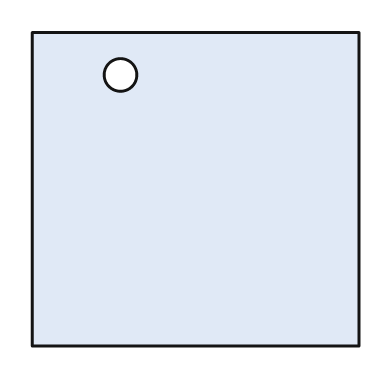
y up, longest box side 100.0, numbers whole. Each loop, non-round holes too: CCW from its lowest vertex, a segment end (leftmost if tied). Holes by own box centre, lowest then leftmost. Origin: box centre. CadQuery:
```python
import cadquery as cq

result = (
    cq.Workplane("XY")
    .moveTo(-50.0, -48.0)
    .lineTo(50.0, -48.0)
    .lineTo(50.0, 48.0)
    .lineTo(-50.0, 48.0)
    .close()
    .moveTo(-23.0, 35.0)
    .circle(5.0)
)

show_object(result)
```